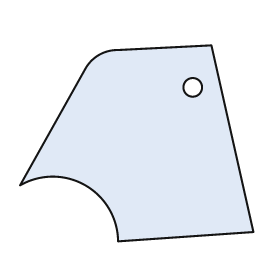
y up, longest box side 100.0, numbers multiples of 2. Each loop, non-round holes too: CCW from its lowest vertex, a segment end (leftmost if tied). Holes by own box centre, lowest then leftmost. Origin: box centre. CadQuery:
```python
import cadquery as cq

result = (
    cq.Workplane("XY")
    .moveTo(-8.0, -42.0)
    .lineTo(50.0, -38.0)
    .lineTo(32.0, 42.0)
    .lineTo(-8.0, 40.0)
    .threePointArc((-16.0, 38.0), (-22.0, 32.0))
    .lineTo(-50.0, -18.0)
    .threePointArc((-22.0, -18.0), (-8.0, -42.0))
    .close()
    .moveTo(24.0, 24.0)
    .circle(4.0)
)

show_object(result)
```